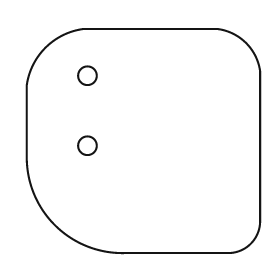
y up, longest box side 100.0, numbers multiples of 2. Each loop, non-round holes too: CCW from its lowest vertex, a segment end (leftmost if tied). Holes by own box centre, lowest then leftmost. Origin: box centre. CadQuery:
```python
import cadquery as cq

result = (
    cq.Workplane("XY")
    .moveTo(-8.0, -48.0)
    .lineTo(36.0, -48.0)
    .threePointArc((46.0, -44.0), (50.0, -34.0))
    .lineTo(50.0, 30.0)
    .threePointArc((44.0, 42.0), (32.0, 48.0))
    .lineTo(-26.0, 48.0)
    .threePointArc((-42.0, 40.0), (-50.0, 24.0))
    .lineTo(-50.0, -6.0)
    .threePointArc((-38.0, -36.0), (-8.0, -48.0))
    .close()
    .moveTo(-24.0, -2.0)
    .circle(4.0)
    .moveTo(-24.0, 28.0)
    .circle(4.0)
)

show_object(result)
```